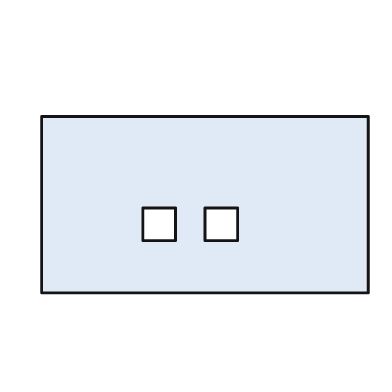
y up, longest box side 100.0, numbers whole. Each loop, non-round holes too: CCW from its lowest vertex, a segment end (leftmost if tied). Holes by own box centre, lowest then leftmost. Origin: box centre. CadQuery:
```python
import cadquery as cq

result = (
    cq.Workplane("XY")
    .moveTo(-50.0, -27.0)
    .lineTo(50.0, -27.0)
    .lineTo(50.0, 27.0)
    .lineTo(-50.0, 27.0)
    .close()
    .moveTo(-19.0, -11.0)
    .lineTo(-9.0, -11.0)
    .lineTo(-9.0, -1.0)
    .lineTo(-19.0, -1.0)
    .close()
    .moveTo(0.0, -11.0)
    .lineTo(10.0, -11.0)
    .lineTo(10.0, -1.0)
    .lineTo(0.0, -1.0)
    .close()
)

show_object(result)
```